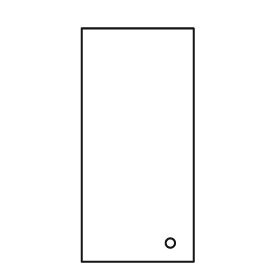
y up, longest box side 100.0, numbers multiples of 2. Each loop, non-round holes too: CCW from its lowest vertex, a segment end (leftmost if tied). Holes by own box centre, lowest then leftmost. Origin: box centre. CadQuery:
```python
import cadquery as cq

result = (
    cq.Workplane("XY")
    .moveTo(-24.0, -50.0)
    .lineTo(24.0, -50.0)
    .lineTo(24.0, 50.0)
    .lineTo(-24.0, 50.0)
    .close()
    .moveTo(14.0, -42.0)
    .circle(2.0)
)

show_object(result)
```